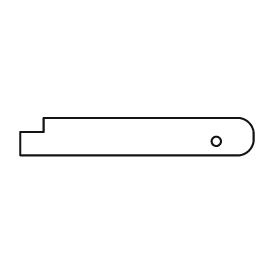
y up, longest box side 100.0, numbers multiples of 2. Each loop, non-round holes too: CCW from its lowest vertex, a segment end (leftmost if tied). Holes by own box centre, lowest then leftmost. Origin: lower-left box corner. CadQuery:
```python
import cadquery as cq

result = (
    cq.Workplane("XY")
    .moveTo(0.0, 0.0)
    .lineTo(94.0, 0.0)
    .threePointArc((98.0, 2.0), (100.0, 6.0))
    .lineTo(100.0, 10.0)
    .threePointArc((98.0, 14.0), (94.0, 16.0))
    .lineTo(10.0, 16.0)
    .lineTo(10.0, 10.0)
    .lineTo(0.0, 10.0)
    .close()
    .moveTo(84.0, 6.0)
    .circle(2.0)
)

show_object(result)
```